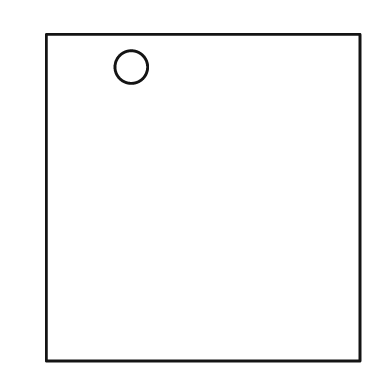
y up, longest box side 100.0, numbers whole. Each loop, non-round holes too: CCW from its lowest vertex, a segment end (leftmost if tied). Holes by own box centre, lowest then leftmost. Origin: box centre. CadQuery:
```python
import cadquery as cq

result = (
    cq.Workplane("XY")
    .moveTo(-48.0, -50.0)
    .lineTo(48.0, -50.0)
    .lineTo(48.0, 50.0)
    .lineTo(-48.0, 50.0)
    .close()
    .moveTo(-22.0, 40.0)
    .circle(5.0)
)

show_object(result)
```